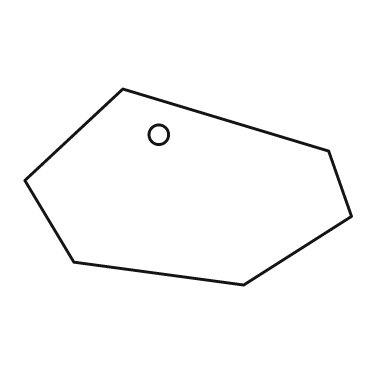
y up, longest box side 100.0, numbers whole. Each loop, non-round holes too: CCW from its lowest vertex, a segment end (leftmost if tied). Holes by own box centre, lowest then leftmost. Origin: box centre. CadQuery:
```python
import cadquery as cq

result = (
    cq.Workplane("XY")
    .moveTo(17.0, -30.0)
    .lineTo(50.0, -9.0)
    .lineTo(43.0, 11.0)
    .lineTo(-20.0, 30.0)
    .lineTo(-50.0, 2.0)
    .lineTo(-35.0, -23.0)
    .close()
    .moveTo(-9.0, 16.0)
    .circle(3.0)
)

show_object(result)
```